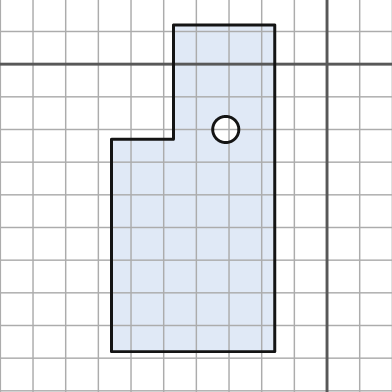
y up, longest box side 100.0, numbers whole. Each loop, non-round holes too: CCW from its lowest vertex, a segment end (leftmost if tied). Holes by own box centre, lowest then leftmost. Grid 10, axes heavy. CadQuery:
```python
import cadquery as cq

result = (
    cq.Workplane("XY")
    .moveTo(-66.0, -88.0)
    .lineTo(-16.0, -88.0)
    .lineTo(-16.0, 12.0)
    .lineTo(-47.0, 12.0)
    .lineTo(-47.0, -23.0)
    .lineTo(-66.0, -23.0)
    .close()
    .moveTo(-31.0, -20.0)
    .circle(4.0)
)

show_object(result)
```